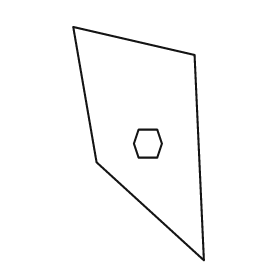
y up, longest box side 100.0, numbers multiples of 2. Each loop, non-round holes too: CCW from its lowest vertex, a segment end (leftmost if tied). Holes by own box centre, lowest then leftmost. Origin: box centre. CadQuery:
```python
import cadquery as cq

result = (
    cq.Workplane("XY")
    .moveTo(28.0, -50.0)
    .lineTo(24.0, 38.0)
    .lineTo(-28.0, 50.0)
    .lineTo(-18.0, -8.0)
    .close()
    .moveTo(0.0, -6.0)
    .lineTo(8.0, -6.0)
    .lineTo(10.0, 0.0)
    .lineTo(8.0, 6.0)
    .lineTo(0.0, 6.0)
    .lineTo(-2.0, 0.0)
    .close()
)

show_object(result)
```